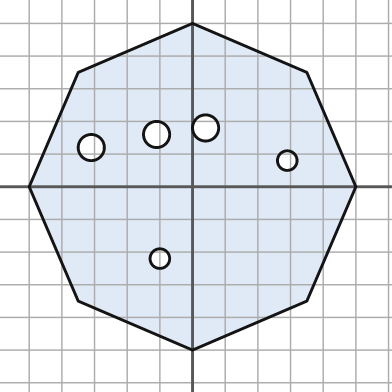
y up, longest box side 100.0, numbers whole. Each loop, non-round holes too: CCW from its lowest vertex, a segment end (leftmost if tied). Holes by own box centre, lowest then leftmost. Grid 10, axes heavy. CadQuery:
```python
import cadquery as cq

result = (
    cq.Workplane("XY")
    .moveTo(0.0, -50.0)
    .lineTo(35.0, -35.0)
    .lineTo(50.0, 0.0)
    .lineTo(35.0, 35.0)
    .lineTo(0.0, 50.0)
    .lineTo(-35.0, 35.0)
    .lineTo(-50.0, 0.0)
    .lineTo(-35.0, -35.0)
    .close()
    .moveTo(-10.0, -22.0)
    .circle(3.0)
    .moveTo(29.0, 8.0)
    .circle(3.0)
    .moveTo(-31.0, 12.0)
    .circle(4.0)
    .moveTo(-11.0, 16.0)
    .circle(4.0)
    .moveTo(4.0, 18.0)
    .circle(4.0)
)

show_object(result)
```